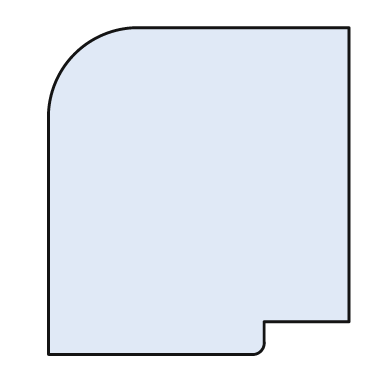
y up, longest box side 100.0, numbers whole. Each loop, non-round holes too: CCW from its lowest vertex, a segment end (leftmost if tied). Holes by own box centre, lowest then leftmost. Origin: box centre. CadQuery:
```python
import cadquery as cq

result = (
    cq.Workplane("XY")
    .moveTo(-46.0, -50.0)
    .lineTo(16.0, -50.0)
    .threePointArc((19.0, -49.0), (20.0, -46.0))
    .lineTo(20.0, -40.0)
    .lineTo(46.0, -40.0)
    .lineTo(46.0, 50.0)
    .lineTo(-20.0, 50.0)
    .threePointArc((-38.0, 42.0), (-46.0, 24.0))
    .close()
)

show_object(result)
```